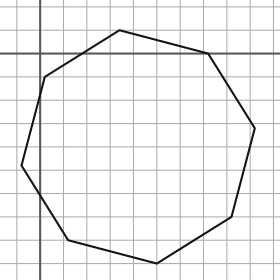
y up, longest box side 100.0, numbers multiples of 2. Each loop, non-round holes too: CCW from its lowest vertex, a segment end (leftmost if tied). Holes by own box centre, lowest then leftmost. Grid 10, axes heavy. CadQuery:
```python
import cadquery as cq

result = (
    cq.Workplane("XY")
    .moveTo(50.0, -90.0)
    .lineTo(82.0, -70.0)
    .lineTo(92.0, -32.0)
    .lineTo(72.0, 0.0)
    .lineTo(34.0, 10.0)
    .lineTo(2.0, -10.0)
    .lineTo(-8.0, -48.0)
    .lineTo(12.0, -80.0)
    .close()
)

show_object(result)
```